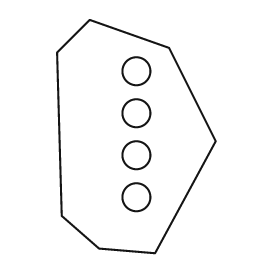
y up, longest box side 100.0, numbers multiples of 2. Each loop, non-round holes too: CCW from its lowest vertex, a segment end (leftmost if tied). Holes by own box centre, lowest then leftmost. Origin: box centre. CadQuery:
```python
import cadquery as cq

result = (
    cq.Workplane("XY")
    .moveTo(8.0, -50.0)
    .lineTo(34.0, -2.0)
    .lineTo(14.0, 38.0)
    .lineTo(-20.0, 50.0)
    .lineTo(-34.0, 36.0)
    .lineTo(-32.0, -34.0)
    .lineTo(-16.0, -48.0)
    .close()
    .moveTo(0.0, -26.0)
    .circle(6.0)
    .moveTo(0.0, -8.0)
    .circle(6.0)
    .moveTo(0.0, 10.0)
    .circle(6.0)
    .moveTo(0.0, 28.0)
    .circle(6.0)
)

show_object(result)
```